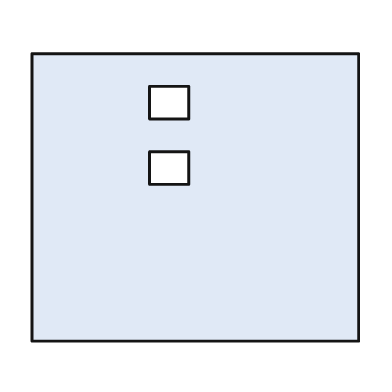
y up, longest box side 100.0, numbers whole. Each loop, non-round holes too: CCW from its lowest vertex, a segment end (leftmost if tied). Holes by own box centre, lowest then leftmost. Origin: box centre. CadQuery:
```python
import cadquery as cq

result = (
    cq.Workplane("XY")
    .moveTo(-50.0, -44.0)
    .lineTo(50.0, -44.0)
    .lineTo(50.0, 44.0)
    .lineTo(-50.0, 44.0)
    .close()
    .moveTo(-14.0, 4.0)
    .lineTo(-2.0, 4.0)
    .lineTo(-2.0, 14.0)
    .lineTo(-14.0, 14.0)
    .close()
    .moveTo(-14.0, 24.0)
    .lineTo(-2.0, 24.0)
    .lineTo(-2.0, 34.0)
    .lineTo(-14.0, 34.0)
    .close()
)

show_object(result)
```